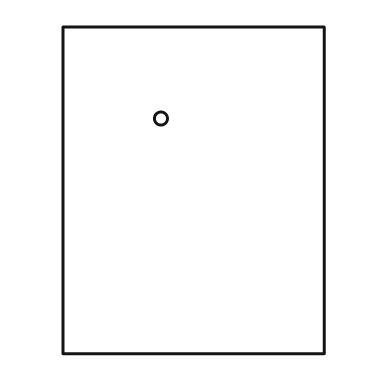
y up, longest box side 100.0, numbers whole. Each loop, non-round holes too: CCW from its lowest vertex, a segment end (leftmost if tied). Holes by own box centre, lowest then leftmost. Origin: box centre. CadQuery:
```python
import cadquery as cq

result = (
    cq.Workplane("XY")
    .moveTo(-40.0, -50.0)
    .lineTo(40.0, -50.0)
    .lineTo(40.0, 50.0)
    .lineTo(-40.0, 50.0)
    .close()
    .moveTo(-10.0, 22.0)
    .circle(2.0)
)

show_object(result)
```